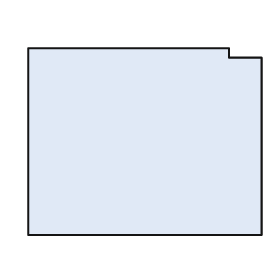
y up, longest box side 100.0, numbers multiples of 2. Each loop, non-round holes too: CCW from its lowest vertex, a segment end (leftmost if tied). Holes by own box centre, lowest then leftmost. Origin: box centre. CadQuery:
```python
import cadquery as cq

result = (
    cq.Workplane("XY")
    .moveTo(-50.0, -40.0)
    .lineTo(50.0, -40.0)
    .lineTo(50.0, 36.0)
    .lineTo(36.0, 36.0)
    .lineTo(36.0, 40.0)
    .lineTo(-50.0, 40.0)
    .close()
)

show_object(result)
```